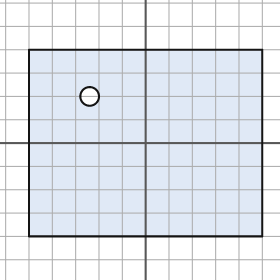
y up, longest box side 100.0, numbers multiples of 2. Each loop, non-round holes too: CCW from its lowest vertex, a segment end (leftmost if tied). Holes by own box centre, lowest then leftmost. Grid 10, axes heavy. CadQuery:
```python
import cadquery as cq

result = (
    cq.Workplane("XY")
    .moveTo(-50.0, -40.0)
    .lineTo(50.0, -40.0)
    .lineTo(50.0, 40.0)
    .lineTo(-50.0, 40.0)
    .close()
    .moveTo(-24.0, 20.0)
    .circle(4.0)
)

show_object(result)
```